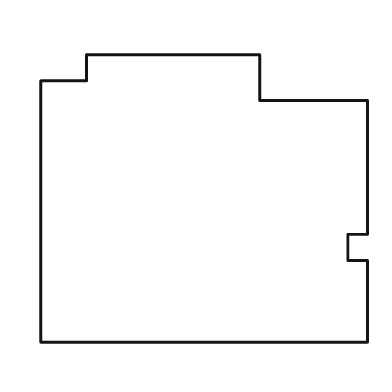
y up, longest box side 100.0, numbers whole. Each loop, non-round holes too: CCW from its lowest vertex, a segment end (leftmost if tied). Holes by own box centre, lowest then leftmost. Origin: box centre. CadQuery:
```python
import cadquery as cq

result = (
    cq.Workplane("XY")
    .moveTo(-50.0, -44.0)
    .lineTo(50.0, -44.0)
    .lineTo(50.0, -19.0)
    .lineTo(44.0, -19.0)
    .lineTo(44.0, -11.0)
    .lineTo(50.0, -11.0)
    .lineTo(50.0, 30.0)
    .lineTo(17.0, 30.0)
    .lineTo(17.0, 44.0)
    .lineTo(-36.0, 44.0)
    .lineTo(-36.0, 36.0)
    .lineTo(-50.0, 36.0)
    .close()
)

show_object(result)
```